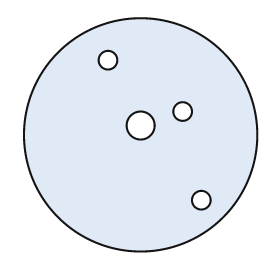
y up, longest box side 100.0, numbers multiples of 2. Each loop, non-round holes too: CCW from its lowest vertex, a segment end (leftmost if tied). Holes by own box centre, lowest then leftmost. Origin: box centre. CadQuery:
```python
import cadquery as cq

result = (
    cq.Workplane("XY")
    .moveTo(0.0, 0.0)
    .circle(50.0)
    .moveTo(26.0, -28.0)
    .circle(4.0)
    .moveTo(0.0, 4.0)
    .circle(6.0)
    .moveTo(18.0, 10.0)
    .circle(4.0)
    .moveTo(-14.0, 32.0)
    .circle(4.0)
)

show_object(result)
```